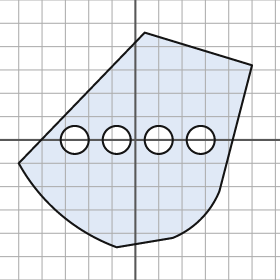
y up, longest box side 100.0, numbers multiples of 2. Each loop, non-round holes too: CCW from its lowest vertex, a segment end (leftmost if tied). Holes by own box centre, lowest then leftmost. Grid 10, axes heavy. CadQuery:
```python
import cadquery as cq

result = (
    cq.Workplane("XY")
    .moveTo(-8.0, -46.0)
    .lineTo(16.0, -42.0)
    .threePointArc((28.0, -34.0), (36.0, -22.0))
    .lineTo(50.0, 32.0)
    .lineTo(4.0, 46.0)
    .lineTo(-50.0, -10.0)
    .threePointArc((-32.0, -32.0), (-8.0, -46.0))
    .close()
    .moveTo(-26.0, 0.0)
    .circle(6.0)
    .moveTo(-8.0, 0.0)
    .circle(6.0)
    .moveTo(10.0, 0.0)
    .circle(6.0)
    .moveTo(28.0, 0.0)
    .circle(6.0)
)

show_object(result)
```